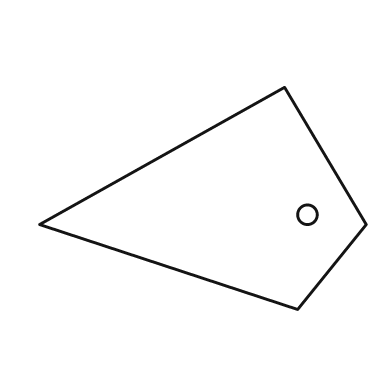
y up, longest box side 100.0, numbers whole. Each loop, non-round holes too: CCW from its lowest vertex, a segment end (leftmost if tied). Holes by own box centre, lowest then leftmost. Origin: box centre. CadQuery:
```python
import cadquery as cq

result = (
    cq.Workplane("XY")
    .moveTo(29.0, -34.0)
    .lineTo(50.0, -8.0)
    .lineTo(25.0, 34.0)
    .lineTo(-50.0, -8.0)
    .close()
    .moveTo(32.0, -5.0)
    .circle(3.0)
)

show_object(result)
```